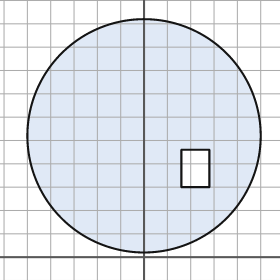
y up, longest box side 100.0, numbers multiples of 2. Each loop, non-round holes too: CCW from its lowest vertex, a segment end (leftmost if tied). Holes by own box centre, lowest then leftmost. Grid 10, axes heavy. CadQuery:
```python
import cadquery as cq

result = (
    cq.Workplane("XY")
    .moveTo(0.0, 52.0)
    .circle(50.0)
    .moveTo(16.0, 30.0)
    .lineTo(28.0, 30.0)
    .lineTo(28.0, 46.0)
    .lineTo(16.0, 46.0)
    .close()
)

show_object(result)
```